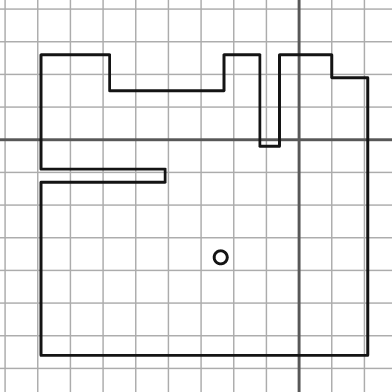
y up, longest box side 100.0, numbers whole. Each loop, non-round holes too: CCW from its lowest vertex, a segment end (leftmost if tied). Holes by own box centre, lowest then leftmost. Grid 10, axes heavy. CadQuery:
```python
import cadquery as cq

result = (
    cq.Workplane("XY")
    .moveTo(-79.0, -66.0)
    .lineTo(21.0, -66.0)
    .lineTo(21.0, 19.0)
    .lineTo(10.0, 19.0)
    .lineTo(10.0, 26.0)
    .lineTo(-6.0, 26.0)
    .lineTo(-6.0, -2.0)
    .lineTo(-12.0, -2.0)
    .lineTo(-12.0, 26.0)
    .lineTo(-23.0, 26.0)
    .lineTo(-23.0, 15.0)
    .lineTo(-58.0, 15.0)
    .lineTo(-58.0, 26.0)
    .lineTo(-79.0, 26.0)
    .lineTo(-79.0, -9.0)
    .lineTo(-41.0, -9.0)
    .lineTo(-41.0, -13.0)
    .lineTo(-79.0, -13.0)
    .close()
    .moveTo(-24.0, -36.0)
    .circle(2.0)
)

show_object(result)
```